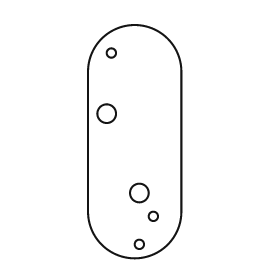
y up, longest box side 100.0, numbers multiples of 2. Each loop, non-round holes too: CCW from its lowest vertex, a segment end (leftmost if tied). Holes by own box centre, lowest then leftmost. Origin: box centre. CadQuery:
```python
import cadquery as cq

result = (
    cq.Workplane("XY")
    .moveTo(-20.0, -30.0)
    .threePointArc((0.0, -50.0), (20.0, -30.0))
    .lineTo(20.0, 30.0)
    .threePointArc((0.0, 50.0), (-20.0, 30.0))
    .close()
    .moveTo(2.0, -44.0)
    .circle(2.0)
    .moveTo(8.0, -32.0)
    .circle(2.0)
    .moveTo(2.0, -22.0)
    .circle(4.0)
    .moveTo(-12.0, 12.0)
    .circle(4.0)
    .moveTo(-10.0, 38.0)
    .circle(2.0)
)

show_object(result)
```